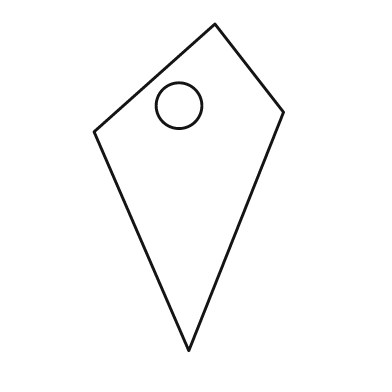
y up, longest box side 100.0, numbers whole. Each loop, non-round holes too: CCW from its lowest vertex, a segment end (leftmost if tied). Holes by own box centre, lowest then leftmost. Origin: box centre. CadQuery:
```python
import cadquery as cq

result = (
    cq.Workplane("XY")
    .moveTo(0.0, -50.0)
    .lineTo(29.0, 23.0)
    .lineTo(8.0, 50.0)
    .lineTo(-29.0, 17.0)
    .close()
    .moveTo(-3.0, 25.0)
    .circle(7.0)
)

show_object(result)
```